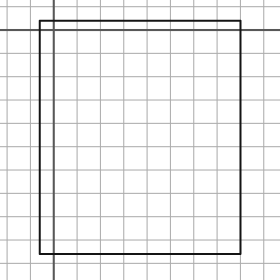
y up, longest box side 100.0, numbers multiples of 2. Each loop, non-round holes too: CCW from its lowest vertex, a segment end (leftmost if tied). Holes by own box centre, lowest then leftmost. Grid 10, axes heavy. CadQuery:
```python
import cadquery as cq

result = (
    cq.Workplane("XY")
    .moveTo(-6.0, -96.0)
    .lineTo(80.0, -96.0)
    .lineTo(80.0, 4.0)
    .lineTo(-6.0, 4.0)
    .close()
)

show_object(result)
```